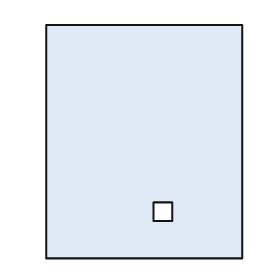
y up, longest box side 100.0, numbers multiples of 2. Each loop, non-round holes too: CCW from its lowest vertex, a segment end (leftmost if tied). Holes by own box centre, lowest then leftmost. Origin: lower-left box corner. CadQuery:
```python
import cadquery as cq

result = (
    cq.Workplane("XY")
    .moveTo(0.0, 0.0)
    .lineTo(84.0, 0.0)
    .lineTo(84.0, 100.0)
    .lineTo(0.0, 100.0)
    .close()
    .moveTo(46.0, 16.0)
    .lineTo(54.0, 16.0)
    .lineTo(54.0, 24.0)
    .lineTo(46.0, 24.0)
    .close()
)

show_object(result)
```